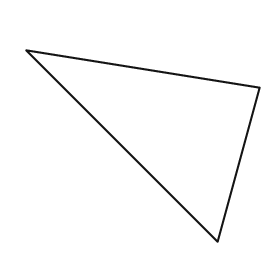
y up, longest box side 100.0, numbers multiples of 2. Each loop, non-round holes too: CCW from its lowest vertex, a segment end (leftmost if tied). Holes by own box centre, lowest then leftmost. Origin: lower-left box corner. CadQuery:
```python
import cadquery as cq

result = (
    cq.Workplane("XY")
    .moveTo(82.0, 0.0)
    .lineTo(100.0, 66.0)
    .lineTo(0.0, 82.0)
    .close()
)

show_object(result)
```